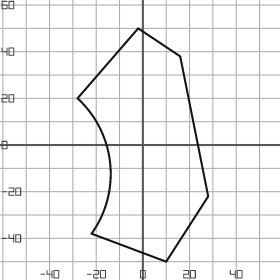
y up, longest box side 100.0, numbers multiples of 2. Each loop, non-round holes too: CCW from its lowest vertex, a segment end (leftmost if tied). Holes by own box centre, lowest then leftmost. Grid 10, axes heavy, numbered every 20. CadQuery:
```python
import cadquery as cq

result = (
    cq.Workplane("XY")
    .moveTo(10.0, -50.0)
    .lineTo(28.0, -22.0)
    .lineTo(16.0, 38.0)
    .lineTo(-2.0, 50.0)
    .lineTo(-28.0, 20.0)
    .threePointArc((-14.0, -8.0), (-22.0, -38.0))
    .close()
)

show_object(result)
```